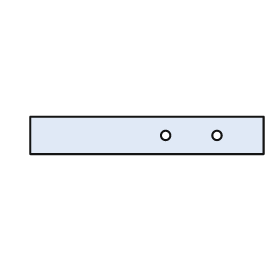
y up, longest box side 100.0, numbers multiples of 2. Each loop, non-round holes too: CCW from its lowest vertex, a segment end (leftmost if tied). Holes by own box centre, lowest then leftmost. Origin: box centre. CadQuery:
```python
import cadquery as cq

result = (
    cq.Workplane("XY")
    .moveTo(-50.0, -8.0)
    .lineTo(50.0, -8.0)
    .lineTo(50.0, 8.0)
    .lineTo(-50.0, 8.0)
    .close()
    .moveTo(8.0, 0.0)
    .circle(2.0)
    .moveTo(30.0, 0.0)
    .circle(2.0)
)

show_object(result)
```